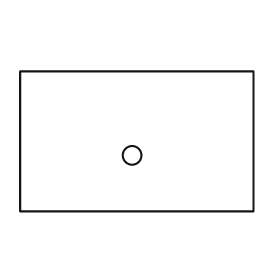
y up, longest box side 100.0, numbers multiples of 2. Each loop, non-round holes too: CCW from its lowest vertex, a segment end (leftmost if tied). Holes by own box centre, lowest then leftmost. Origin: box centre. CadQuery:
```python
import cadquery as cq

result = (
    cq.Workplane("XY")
    .moveTo(-50.0, -30.0)
    .lineTo(50.0, -30.0)
    .lineTo(50.0, 30.0)
    .lineTo(-50.0, 30.0)
    .close()
    .moveTo(-2.0, -6.0)
    .circle(4.0)
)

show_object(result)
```